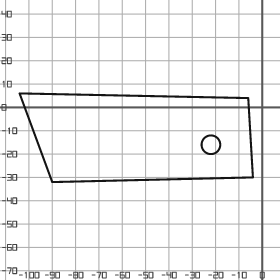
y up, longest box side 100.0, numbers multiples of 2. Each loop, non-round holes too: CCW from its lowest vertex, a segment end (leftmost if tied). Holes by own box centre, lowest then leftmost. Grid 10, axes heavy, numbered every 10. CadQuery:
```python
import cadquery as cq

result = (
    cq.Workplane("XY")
    .moveTo(-90.0, -32.0)
    .lineTo(-4.0, -30.0)
    .lineTo(-6.0, 4.0)
    .lineTo(-104.0, 6.0)
    .close()
    .moveTo(-22.0, -16.0)
    .circle(4.0)
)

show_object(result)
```